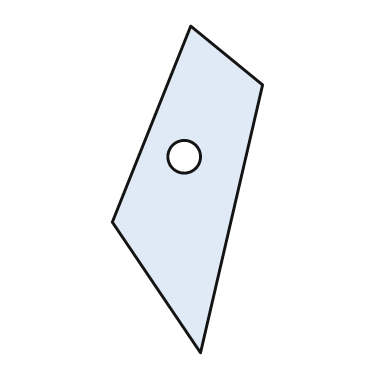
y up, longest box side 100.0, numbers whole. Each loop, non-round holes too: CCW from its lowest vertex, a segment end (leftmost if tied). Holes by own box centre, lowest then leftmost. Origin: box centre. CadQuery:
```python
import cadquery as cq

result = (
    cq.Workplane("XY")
    .moveTo(4.0, -50.0)
    .lineTo(23.0, 32.0)
    .lineTo(1.0, 50.0)
    .lineTo(-23.0, -10.0)
    .close()
    .moveTo(-1.0, 10.0)
    .circle(5.0)
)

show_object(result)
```